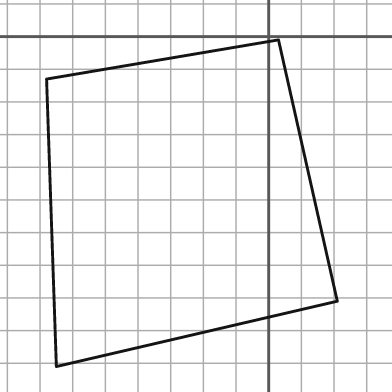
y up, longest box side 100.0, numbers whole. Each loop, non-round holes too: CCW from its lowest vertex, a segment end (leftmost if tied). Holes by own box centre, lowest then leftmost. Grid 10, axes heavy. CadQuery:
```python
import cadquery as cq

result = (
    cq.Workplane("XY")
    .moveTo(-65.0, -101.0)
    .lineTo(21.0, -81.0)
    .lineTo(3.0, -1.0)
    .lineTo(-68.0, -13.0)
    .close()
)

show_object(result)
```